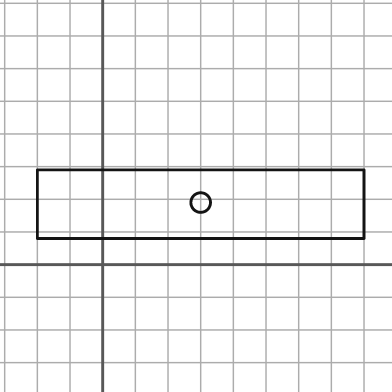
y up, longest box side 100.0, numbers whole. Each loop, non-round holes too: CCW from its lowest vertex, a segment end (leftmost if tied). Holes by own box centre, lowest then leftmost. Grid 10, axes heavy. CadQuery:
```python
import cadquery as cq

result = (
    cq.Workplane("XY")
    .moveTo(-20.0, 8.0)
    .lineTo(80.0, 8.0)
    .lineTo(80.0, 29.0)
    .lineTo(-20.0, 29.0)
    .close()
    .moveTo(30.0, 19.0)
    .circle(3.0)
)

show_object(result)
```